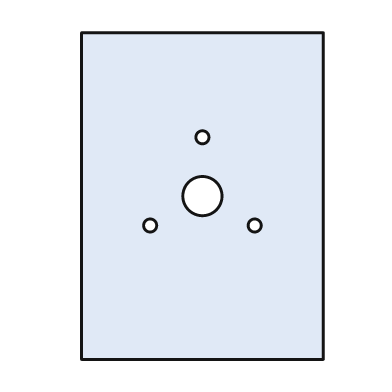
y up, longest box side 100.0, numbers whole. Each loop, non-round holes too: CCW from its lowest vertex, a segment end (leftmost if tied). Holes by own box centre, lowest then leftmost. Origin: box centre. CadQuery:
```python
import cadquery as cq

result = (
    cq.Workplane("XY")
    .moveTo(-37.0, -50.0)
    .lineTo(37.0, -50.0)
    .lineTo(37.0, 50.0)
    .lineTo(-37.0, 50.0)
    .close()
    .moveTo(-16.0, -9.0)
    .circle(2.0)
    .moveTo(16.0, -9.0)
    .circle(2.0)
    .moveTo(0.0, 0.0)
    .circle(6.0)
    .moveTo(0.0, 18.0)
    .circle(2.0)
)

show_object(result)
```